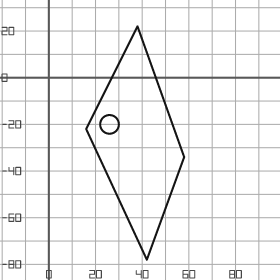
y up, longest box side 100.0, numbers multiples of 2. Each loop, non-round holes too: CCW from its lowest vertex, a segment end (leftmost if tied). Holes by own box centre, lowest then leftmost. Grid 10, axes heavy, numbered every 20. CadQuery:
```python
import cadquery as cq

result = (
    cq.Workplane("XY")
    .moveTo(42.0, -78.0)
    .lineTo(58.0, -34.0)
    .lineTo(38.0, 22.0)
    .lineTo(16.0, -22.0)
    .close()
    .moveTo(26.0, -20.0)
    .circle(4.0)
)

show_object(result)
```